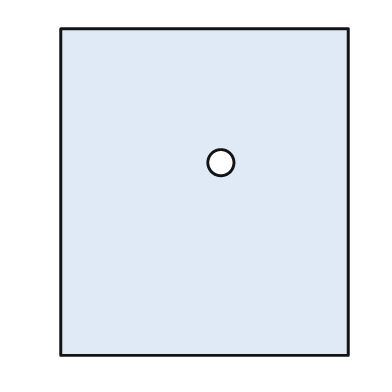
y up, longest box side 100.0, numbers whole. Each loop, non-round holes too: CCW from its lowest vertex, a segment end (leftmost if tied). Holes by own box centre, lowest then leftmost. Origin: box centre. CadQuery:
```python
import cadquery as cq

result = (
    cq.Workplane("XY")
    .moveTo(-44.0, -50.0)
    .lineTo(44.0, -50.0)
    .lineTo(44.0, 50.0)
    .lineTo(-44.0, 50.0)
    .close()
    .moveTo(5.0, 9.0)
    .circle(4.0)
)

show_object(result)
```